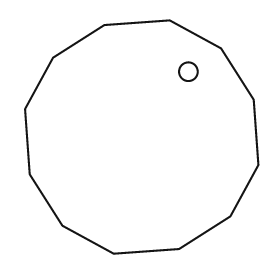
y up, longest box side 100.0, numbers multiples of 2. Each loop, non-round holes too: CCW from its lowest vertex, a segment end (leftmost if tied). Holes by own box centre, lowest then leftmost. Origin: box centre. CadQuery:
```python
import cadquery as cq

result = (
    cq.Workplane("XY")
    .moveTo(-12.0, -50.0)
    .lineTo(16.0, -48.0)
    .lineTo(38.0, -34.0)
    .lineTo(50.0, -12.0)
    .lineTo(48.0, 16.0)
    .lineTo(34.0, 38.0)
    .lineTo(12.0, 50.0)
    .lineTo(-16.0, 48.0)
    .lineTo(-38.0, 34.0)
    .lineTo(-50.0, 12.0)
    .lineTo(-48.0, -16.0)
    .lineTo(-34.0, -38.0)
    .close()
    .moveTo(20.0, 28.0)
    .circle(4.0)
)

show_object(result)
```